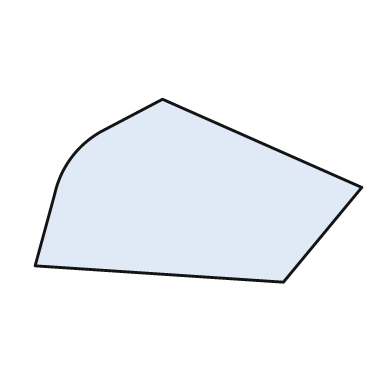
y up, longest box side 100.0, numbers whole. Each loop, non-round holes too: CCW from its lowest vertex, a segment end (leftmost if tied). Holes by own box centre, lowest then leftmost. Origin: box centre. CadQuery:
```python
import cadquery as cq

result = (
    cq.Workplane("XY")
    .moveTo(26.0, -28.0)
    .lineTo(50.0, 1.0)
    .lineTo(-11.0, 28.0)
    .lineTo(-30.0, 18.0)
    .threePointArc((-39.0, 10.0), (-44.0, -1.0))
    .lineTo(-50.0, -23.0)
    .close()
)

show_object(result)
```